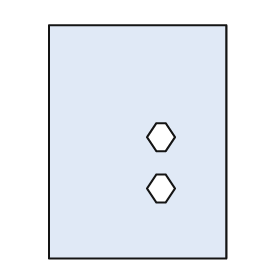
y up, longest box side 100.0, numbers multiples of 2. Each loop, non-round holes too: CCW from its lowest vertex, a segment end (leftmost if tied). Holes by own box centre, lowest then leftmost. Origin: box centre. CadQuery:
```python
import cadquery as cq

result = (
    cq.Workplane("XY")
    .moveTo(-38.0, -50.0)
    .lineTo(38.0, -50.0)
    .lineTo(38.0, 50.0)
    .lineTo(-38.0, 50.0)
    .close()
    .moveTo(8.0, -26.0)
    .lineTo(12.0, -26.0)
    .lineTo(16.0, -20.0)
    .lineTo(12.0, -14.0)
    .lineTo(8.0, -14.0)
    .lineTo(4.0, -20.0)
    .close()
    .moveTo(8.0, -4.0)
    .lineTo(12.0, -4.0)
    .lineTo(16.0, 2.0)
    .lineTo(12.0, 8.0)
    .lineTo(8.0, 8.0)
    .lineTo(4.0, 2.0)
    .close()
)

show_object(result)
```